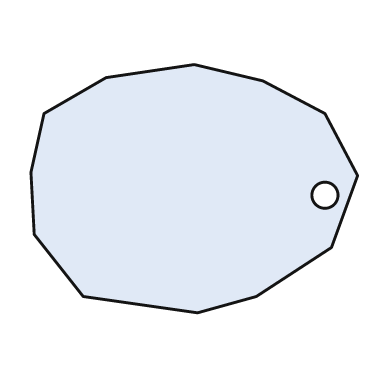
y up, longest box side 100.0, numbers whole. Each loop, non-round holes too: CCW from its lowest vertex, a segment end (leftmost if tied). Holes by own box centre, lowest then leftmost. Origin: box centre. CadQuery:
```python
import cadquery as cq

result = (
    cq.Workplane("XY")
    .moveTo(1.0, -38.0)
    .lineTo(19.0, -33.0)
    .lineTo(42.0, -18.0)
    .lineTo(50.0, 4.0)
    .lineTo(40.0, 23.0)
    .lineTo(21.0, 33.0)
    .lineTo(0.0, 38.0)
    .lineTo(-27.0, 34.0)
    .lineTo(-46.0, 23.0)
    .lineTo(-50.0, 5.0)
    .lineTo(-49.0, -14.0)
    .lineTo(-34.0, -33.0)
    .close()
    .moveTo(40.0, -2.0)
    .circle(4.0)
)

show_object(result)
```